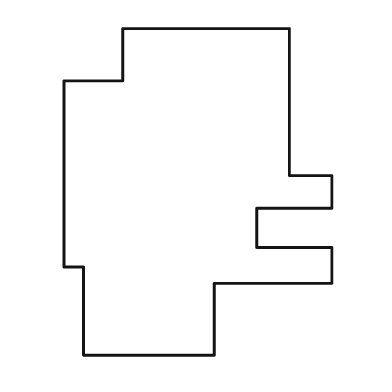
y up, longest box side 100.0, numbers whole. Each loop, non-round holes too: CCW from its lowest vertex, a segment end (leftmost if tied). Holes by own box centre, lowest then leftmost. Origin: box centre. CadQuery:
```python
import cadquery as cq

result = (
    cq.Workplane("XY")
    .moveTo(-35.0, -50.0)
    .lineTo(5.0, -50.0)
    .lineTo(5.0, -28.0)
    .lineTo(41.0, -28.0)
    .lineTo(41.0, -17.0)
    .lineTo(18.0, -17.0)
    .lineTo(18.0, -5.0)
    .lineTo(41.0, -5.0)
    .lineTo(41.0, 5.0)
    .lineTo(28.0, 5.0)
    .lineTo(28.0, 50.0)
    .lineTo(-23.0, 50.0)
    .lineTo(-23.0, 34.0)
    .lineTo(-41.0, 34.0)
    .lineTo(-41.0, -23.0)
    .lineTo(-35.0, -23.0)
    .close()
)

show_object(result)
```